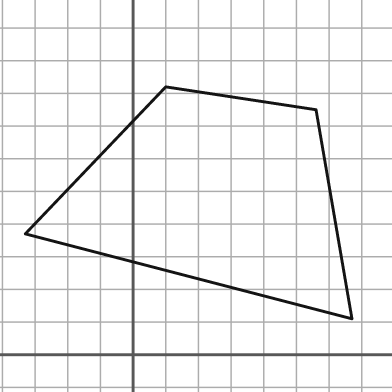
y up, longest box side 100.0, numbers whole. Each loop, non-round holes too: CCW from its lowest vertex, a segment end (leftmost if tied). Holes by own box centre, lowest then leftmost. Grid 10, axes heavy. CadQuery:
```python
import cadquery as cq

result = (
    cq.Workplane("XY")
    .moveTo(67.0, 11.0)
    .lineTo(56.0, 75.0)
    .lineTo(10.0, 82.0)
    .lineTo(-33.0, 37.0)
    .close()
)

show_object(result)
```